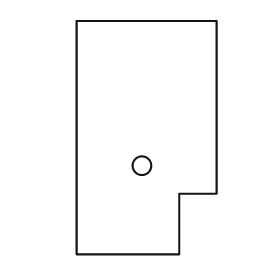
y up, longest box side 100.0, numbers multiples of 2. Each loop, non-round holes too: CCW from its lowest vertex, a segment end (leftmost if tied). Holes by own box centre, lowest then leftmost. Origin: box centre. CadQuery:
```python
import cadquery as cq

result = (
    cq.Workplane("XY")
    .moveTo(-30.0, -50.0)
    .lineTo(14.0, -50.0)
    .lineTo(14.0, -24.0)
    .lineTo(30.0, -24.0)
    .lineTo(30.0, 50.0)
    .lineTo(-30.0, 50.0)
    .close()
    .moveTo(-2.0, -12.0)
    .circle(4.0)
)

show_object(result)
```